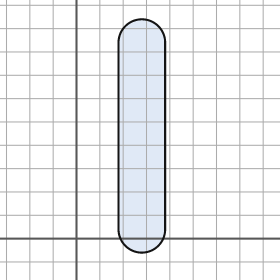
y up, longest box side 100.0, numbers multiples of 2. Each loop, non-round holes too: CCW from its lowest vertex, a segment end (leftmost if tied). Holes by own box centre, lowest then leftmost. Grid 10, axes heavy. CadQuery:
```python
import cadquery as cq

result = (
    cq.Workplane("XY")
    .moveTo(18.0, 4.0)
    .threePointArc((28.0, -6.0), (38.0, 4.0))
    .lineTo(38.0, 84.0)
    .threePointArc((28.0, 94.0), (18.0, 84.0))
    .close()
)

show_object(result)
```